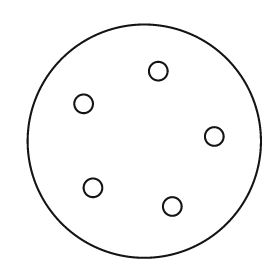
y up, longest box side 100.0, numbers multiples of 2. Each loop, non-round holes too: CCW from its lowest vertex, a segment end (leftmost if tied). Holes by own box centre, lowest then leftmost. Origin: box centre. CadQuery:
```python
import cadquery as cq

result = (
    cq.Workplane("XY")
    .moveTo(0.0, 0.0)
    .circle(50.0)
    .moveTo(12.0, -28.0)
    .circle(4.0)
    .moveTo(-22.0, -20.0)
    .circle(4.0)
    .moveTo(30.0, 2.0)
    .circle(4.0)
    .moveTo(-26.0, 16.0)
    .circle(4.0)
    .moveTo(6.0, 30.0)
    .circle(4.0)
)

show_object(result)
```